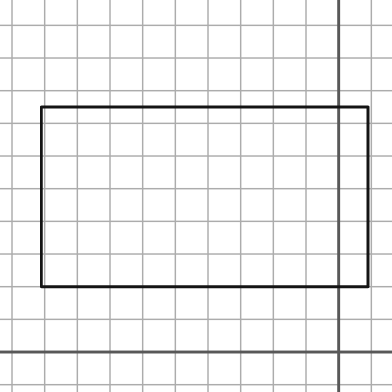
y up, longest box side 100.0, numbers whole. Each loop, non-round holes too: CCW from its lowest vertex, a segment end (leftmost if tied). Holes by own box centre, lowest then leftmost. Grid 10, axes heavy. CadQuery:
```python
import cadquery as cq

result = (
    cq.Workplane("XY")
    .moveTo(-91.0, 20.0)
    .lineTo(9.0, 20.0)
    .lineTo(9.0, 75.0)
    .lineTo(-91.0, 75.0)
    .close()
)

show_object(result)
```